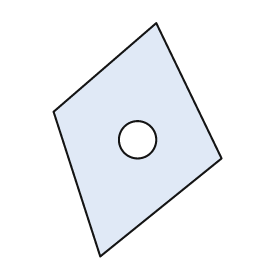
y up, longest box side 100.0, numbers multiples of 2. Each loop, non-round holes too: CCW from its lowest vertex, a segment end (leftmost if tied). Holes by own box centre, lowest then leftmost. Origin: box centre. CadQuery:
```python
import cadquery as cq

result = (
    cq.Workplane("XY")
    .moveTo(-16.0, -50.0)
    .lineTo(36.0, -8.0)
    .lineTo(8.0, 50.0)
    .lineTo(-36.0, 12.0)
    .close()
    .moveTo(0.0, 0.0)
    .circle(8.0)
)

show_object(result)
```